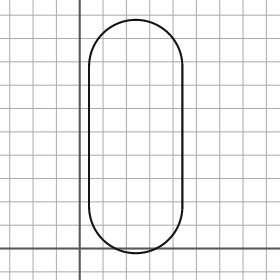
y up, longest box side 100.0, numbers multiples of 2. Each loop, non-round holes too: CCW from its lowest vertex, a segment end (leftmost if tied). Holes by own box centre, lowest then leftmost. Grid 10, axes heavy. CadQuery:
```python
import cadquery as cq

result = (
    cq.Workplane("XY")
    .moveTo(4.0, 18.0)
    .threePointArc((24.0, -2.0), (44.0, 18.0))
    .lineTo(44.0, 78.0)
    .threePointArc((24.0, 98.0), (4.0, 78.0))
    .close()
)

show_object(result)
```